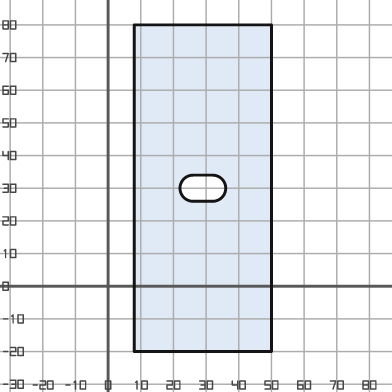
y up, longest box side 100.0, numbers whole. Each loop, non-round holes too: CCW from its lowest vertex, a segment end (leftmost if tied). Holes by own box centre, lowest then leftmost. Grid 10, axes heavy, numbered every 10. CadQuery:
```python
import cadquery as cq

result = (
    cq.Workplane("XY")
    .moveTo(8.0, -20.0)
    .lineTo(50.0, -20.0)
    .lineTo(50.0, 80.0)
    .lineTo(8.0, 80.0)
    .close()
    .moveTo(26.0, 26.0)
    .lineTo(32.0, 26.0)
    .threePointArc((36.0, 30.0), (32.0, 34.0))
    .lineTo(26.0, 34.0)
    .threePointArc((22.0, 30.0), (26.0, 26.0))
    .close()
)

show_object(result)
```